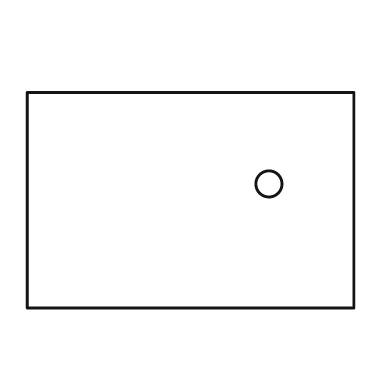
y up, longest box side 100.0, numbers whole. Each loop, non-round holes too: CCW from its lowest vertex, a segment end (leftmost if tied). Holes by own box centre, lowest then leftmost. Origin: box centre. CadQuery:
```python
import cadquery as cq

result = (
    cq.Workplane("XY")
    .moveTo(-50.0, -33.0)
    .lineTo(50.0, -33.0)
    .lineTo(50.0, 33.0)
    .lineTo(-50.0, 33.0)
    .close()
    .moveTo(24.0, 5.0)
    .circle(4.0)
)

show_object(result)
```